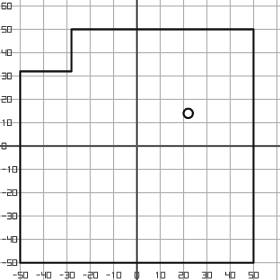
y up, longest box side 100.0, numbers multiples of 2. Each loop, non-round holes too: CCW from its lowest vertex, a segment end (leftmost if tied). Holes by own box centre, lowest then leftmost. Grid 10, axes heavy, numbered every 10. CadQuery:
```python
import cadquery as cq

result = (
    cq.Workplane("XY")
    .moveTo(-50.0, -50.0)
    .lineTo(50.0, -50.0)
    .lineTo(50.0, 50.0)
    .lineTo(-28.0, 50.0)
    .lineTo(-28.0, 32.0)
    .lineTo(-50.0, 32.0)
    .close()
    .moveTo(22.0, 14.0)
    .circle(2.0)
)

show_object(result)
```